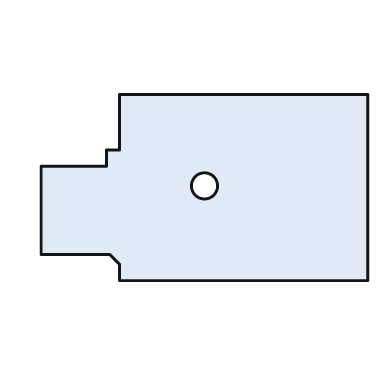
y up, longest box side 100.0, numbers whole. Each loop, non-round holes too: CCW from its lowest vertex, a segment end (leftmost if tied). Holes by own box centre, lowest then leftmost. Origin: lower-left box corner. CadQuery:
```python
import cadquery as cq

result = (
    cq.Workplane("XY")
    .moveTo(24.0, 0.0)
    .lineTo(100.0, 0.0)
    .lineTo(100.0, 57.0)
    .lineTo(24.0, 57.0)
    .lineTo(24.0, 40.0)
    .lineTo(20.0, 40.0)
    .lineTo(20.0, 35.0)
    .lineTo(0.0, 35.0)
    .lineTo(0.0, 8.0)
    .lineTo(21.0, 8.0)
    .lineTo(24.0, 5.0)
    .close()
    .moveTo(50.0, 29.0)
    .circle(4.0)
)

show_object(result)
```